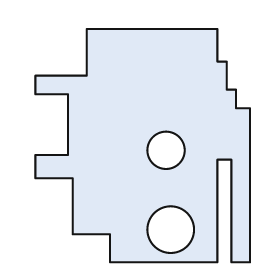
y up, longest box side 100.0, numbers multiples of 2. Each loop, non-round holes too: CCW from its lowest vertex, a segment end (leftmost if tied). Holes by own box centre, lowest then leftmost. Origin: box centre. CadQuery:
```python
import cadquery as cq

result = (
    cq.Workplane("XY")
    .moveTo(-14.0, -50.0)
    .lineTo(32.0, -50.0)
    .lineTo(32.0, -6.0)
    .lineTo(38.0, -6.0)
    .lineTo(38.0, -50.0)
    .lineTo(46.0, -50.0)
    .lineTo(46.0, 16.0)
    .lineTo(40.0, 16.0)
    .lineTo(40.0, 24.0)
    .lineTo(36.0, 24.0)
    .lineTo(36.0, 36.0)
    .lineTo(32.0, 36.0)
    .lineTo(32.0, 50.0)
    .lineTo(-24.0, 50.0)
    .lineTo(-24.0, 30.0)
    .lineTo(-46.0, 30.0)
    .lineTo(-46.0, 22.0)
    .lineTo(-32.0, 22.0)
    .lineTo(-32.0, -4.0)
    .lineTo(-46.0, -4.0)
    .lineTo(-46.0, -14.0)
    .lineTo(-30.0, -14.0)
    .lineTo(-30.0, -38.0)
    .lineTo(-14.0, -38.0)
    .close()
    .moveTo(12.0, -36.0)
    .circle(10.0)
    .moveTo(10.0, -2.0)
    .circle(8.0)
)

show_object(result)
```